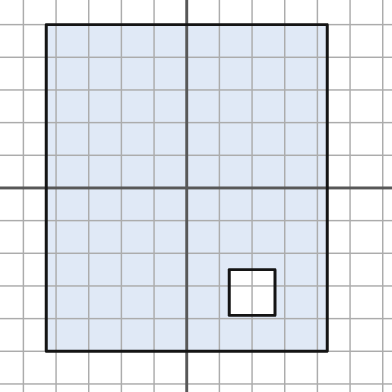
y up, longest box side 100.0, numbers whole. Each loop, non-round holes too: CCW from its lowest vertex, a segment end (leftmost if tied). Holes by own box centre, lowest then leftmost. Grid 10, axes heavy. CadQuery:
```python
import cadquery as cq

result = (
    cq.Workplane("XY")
    .moveTo(-43.0, -50.0)
    .lineTo(43.0, -50.0)
    .lineTo(43.0, 50.0)
    .lineTo(-43.0, 50.0)
    .close()
    .moveTo(13.0, -39.0)
    .lineTo(27.0, -39.0)
    .lineTo(27.0, -25.0)
    .lineTo(13.0, -25.0)
    .close()
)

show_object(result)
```